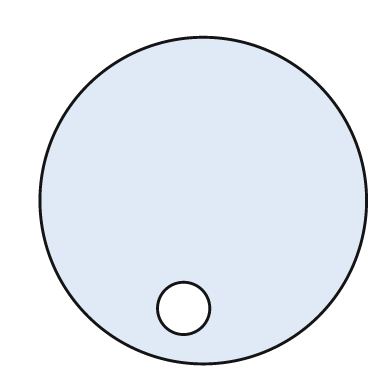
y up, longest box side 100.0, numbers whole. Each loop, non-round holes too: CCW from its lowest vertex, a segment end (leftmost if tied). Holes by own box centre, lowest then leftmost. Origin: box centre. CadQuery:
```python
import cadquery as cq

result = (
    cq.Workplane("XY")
    .moveTo(0.0, 0.0)
    .circle(50.0)
    .moveTo(-6.0, -33.0)
    .circle(8.0)
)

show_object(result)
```